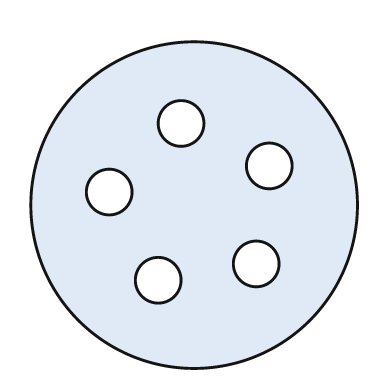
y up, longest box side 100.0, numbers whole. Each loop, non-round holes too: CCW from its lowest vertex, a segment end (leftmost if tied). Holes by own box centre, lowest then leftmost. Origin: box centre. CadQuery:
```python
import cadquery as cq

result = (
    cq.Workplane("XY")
    .moveTo(0.0, 0.0)
    .circle(50.0)
    .moveTo(-11.0, -23.0)
    .circle(7.0)
    .moveTo(19.0, -18.0)
    .circle(7.0)
    .moveTo(-26.0, 4.0)
    .circle(7.0)
    .moveTo(23.0, 12.0)
    .circle(7.0)
    .moveTo(-4.0, 25.0)
    .circle(7.0)
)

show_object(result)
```